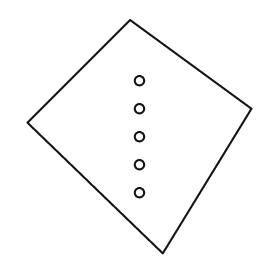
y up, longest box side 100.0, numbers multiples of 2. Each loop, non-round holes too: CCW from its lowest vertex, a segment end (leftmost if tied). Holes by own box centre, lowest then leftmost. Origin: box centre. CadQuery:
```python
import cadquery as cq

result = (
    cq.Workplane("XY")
    .moveTo(10.0, -50.0)
    .lineTo(48.0, 12.0)
    .lineTo(-4.0, 50.0)
    .lineTo(-48.0, 6.0)
    .close()
    .moveTo(0.0, -24.0)
    .circle(2.0)
    .moveTo(0.0, -12.0)
    .circle(2.0)
    .moveTo(0.0, 0.0)
    .circle(2.0)
    .moveTo(0.0, 12.0)
    .circle(2.0)
    .moveTo(0.0, 24.0)
    .circle(2.0)
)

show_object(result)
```